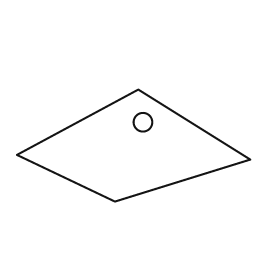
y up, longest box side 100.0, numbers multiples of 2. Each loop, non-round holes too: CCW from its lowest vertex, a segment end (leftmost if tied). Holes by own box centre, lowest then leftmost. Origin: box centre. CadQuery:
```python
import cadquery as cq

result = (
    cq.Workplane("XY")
    .moveTo(-8.0, -24.0)
    .lineTo(50.0, -6.0)
    .lineTo(2.0, 24.0)
    .lineTo(-50.0, -4.0)
    .close()
    .moveTo(4.0, 10.0)
    .circle(4.0)
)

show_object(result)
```